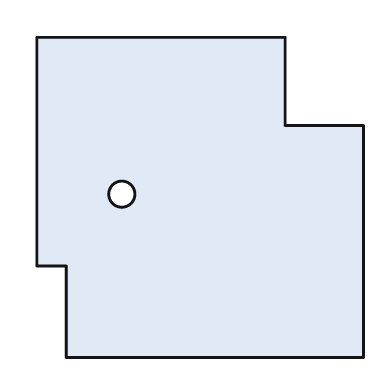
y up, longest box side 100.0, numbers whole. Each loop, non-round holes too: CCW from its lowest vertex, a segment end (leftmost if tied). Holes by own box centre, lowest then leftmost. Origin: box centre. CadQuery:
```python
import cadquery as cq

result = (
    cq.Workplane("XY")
    .moveTo(-41.0, -49.0)
    .lineTo(50.0, -49.0)
    .lineTo(50.0, 22.0)
    .lineTo(26.0, 22.0)
    .lineTo(26.0, 49.0)
    .lineTo(-50.0, 49.0)
    .lineTo(-50.0, -21.0)
    .lineTo(-41.0, -21.0)
    .close()
    .moveTo(-24.0, 1.0)
    .circle(4.0)
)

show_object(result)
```